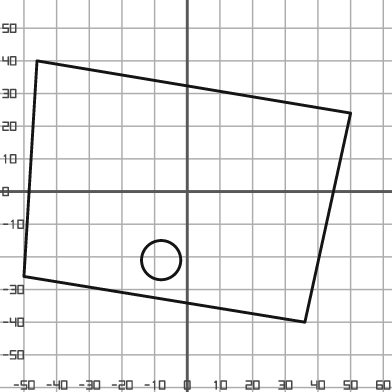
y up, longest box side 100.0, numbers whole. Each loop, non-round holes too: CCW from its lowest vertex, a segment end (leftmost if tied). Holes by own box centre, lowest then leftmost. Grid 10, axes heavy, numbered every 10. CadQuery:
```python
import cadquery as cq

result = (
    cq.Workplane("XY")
    .moveTo(36.0, -40.0)
    .lineTo(50.0, 24.0)
    .lineTo(-46.0, 40.0)
    .lineTo(-50.0, -26.0)
    .close()
    .moveTo(-8.0, -21.0)
    .circle(6.0)
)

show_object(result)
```